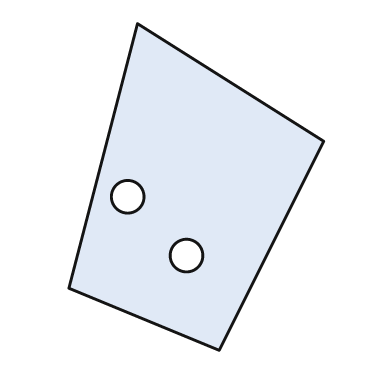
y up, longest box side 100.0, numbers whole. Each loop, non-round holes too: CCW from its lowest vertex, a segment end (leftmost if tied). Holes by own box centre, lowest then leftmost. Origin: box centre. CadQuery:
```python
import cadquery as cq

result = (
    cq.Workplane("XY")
    .moveTo(7.0, -50.0)
    .lineTo(39.0, 14.0)
    .lineTo(-18.0, 50.0)
    .lineTo(-39.0, -31.0)
    .close()
    .moveTo(-3.0, -21.0)
    .circle(5.0)
    .moveTo(-21.0, -3.0)
    .circle(5.0)
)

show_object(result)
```